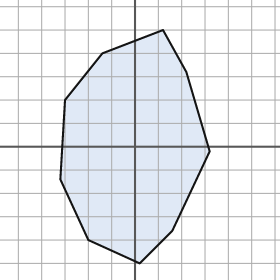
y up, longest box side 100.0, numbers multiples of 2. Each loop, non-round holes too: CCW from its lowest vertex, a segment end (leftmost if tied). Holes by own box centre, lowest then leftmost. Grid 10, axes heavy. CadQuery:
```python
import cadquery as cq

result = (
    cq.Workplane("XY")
    .moveTo(2.0, -50.0)
    .lineTo(16.0, -36.0)
    .lineTo(32.0, -2.0)
    .lineTo(22.0, 32.0)
    .lineTo(12.0, 50.0)
    .lineTo(-14.0, 40.0)
    .lineTo(-30.0, 20.0)
    .lineTo(-32.0, -14.0)
    .lineTo(-20.0, -40.0)
    .close()
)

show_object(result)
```